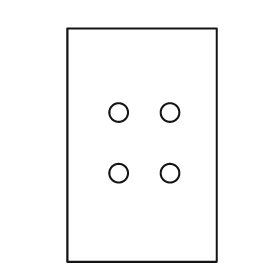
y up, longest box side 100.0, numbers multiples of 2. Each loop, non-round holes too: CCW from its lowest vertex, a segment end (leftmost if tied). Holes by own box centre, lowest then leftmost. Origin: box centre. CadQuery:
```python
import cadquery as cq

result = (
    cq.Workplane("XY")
    .moveTo(-32.0, -50.0)
    .lineTo(32.0, -50.0)
    .lineTo(32.0, 50.0)
    .lineTo(-32.0, 50.0)
    .close()
    .moveTo(-10.0, -12.0)
    .circle(4.0)
    .moveTo(12.0, -12.0)
    .circle(4.0)
    .moveTo(-10.0, 14.0)
    .circle(4.0)
    .moveTo(12.0, 14.0)
    .circle(4.0)
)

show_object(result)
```